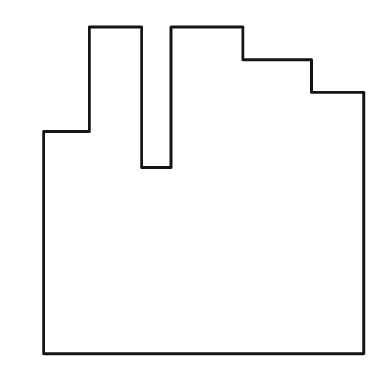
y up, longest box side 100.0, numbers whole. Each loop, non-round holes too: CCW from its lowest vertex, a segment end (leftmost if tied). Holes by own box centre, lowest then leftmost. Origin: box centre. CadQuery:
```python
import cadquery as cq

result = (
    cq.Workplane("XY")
    .moveTo(-49.0, -50.0)
    .lineTo(49.0, -50.0)
    .lineTo(49.0, 30.0)
    .lineTo(33.0, 30.0)
    .lineTo(33.0, 40.0)
    .lineTo(12.0, 40.0)
    .lineTo(12.0, 50.0)
    .lineTo(-10.0, 50.0)
    .lineTo(-10.0, 7.0)
    .lineTo(-19.0, 7.0)
    .lineTo(-19.0, 50.0)
    .lineTo(-35.0, 50.0)
    .lineTo(-35.0, 18.0)
    .lineTo(-49.0, 18.0)
    .close()
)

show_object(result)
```